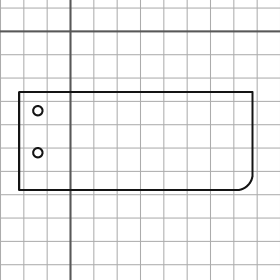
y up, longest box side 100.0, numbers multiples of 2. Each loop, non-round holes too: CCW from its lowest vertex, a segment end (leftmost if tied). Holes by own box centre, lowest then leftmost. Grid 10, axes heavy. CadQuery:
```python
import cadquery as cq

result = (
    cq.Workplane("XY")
    .moveTo(-22.0, -68.0)
    .lineTo(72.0, -68.0)
    .threePointArc((76.0, -66.0), (78.0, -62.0))
    .lineTo(78.0, -26.0)
    .lineTo(-22.0, -26.0)
    .close()
    .moveTo(-14.0, -52.0)
    .circle(2.0)
    .moveTo(-14.0, -34.0)
    .circle(2.0)
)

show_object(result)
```